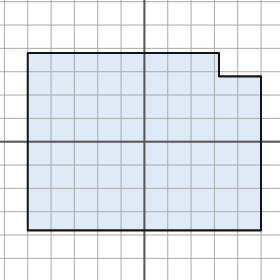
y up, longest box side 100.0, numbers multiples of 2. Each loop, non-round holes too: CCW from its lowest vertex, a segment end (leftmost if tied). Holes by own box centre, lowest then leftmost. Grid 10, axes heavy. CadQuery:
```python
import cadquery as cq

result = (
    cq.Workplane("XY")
    .moveTo(-50.0, -38.0)
    .lineTo(50.0, -38.0)
    .lineTo(50.0, 28.0)
    .lineTo(32.0, 28.0)
    .lineTo(32.0, 38.0)
    .lineTo(-50.0, 38.0)
    .close()
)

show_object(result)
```